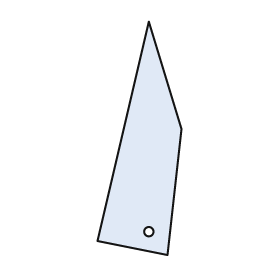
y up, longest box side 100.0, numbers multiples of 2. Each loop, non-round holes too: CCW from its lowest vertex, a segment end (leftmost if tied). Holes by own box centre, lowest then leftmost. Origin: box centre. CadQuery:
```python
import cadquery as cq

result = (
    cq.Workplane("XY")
    .moveTo(12.0, -50.0)
    .lineTo(18.0, 4.0)
    .lineTo(4.0, 50.0)
    .lineTo(-18.0, -44.0)
    .close()
    .moveTo(4.0, -40.0)
    .circle(2.0)
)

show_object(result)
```